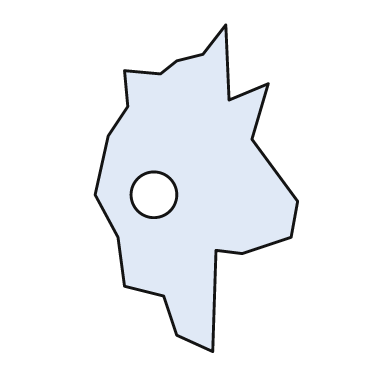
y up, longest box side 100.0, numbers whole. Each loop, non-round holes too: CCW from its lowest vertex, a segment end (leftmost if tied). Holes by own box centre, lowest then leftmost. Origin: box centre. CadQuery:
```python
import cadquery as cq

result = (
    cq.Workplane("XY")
    .moveTo(5.0, -50.0)
    .lineTo(6.0, -19.0)
    .lineTo(14.0, -20.0)
    .lineTo(29.0, -15.0)
    .lineTo(31.0, -4.0)
    .lineTo(17.0, 15.0)
    .lineTo(22.0, 32.0)
    .lineTo(10.0, 27.0)
    .lineTo(9.0, 50.0)
    .lineTo(2.0, 41.0)
    .lineTo(-6.0, 39.0)
    .lineTo(-11.0, 35.0)
    .lineTo(-22.0, 36.0)
    .lineTo(-21.0, 25.0)
    .lineTo(-27.0, 16.0)
    .lineTo(-31.0, -2.0)
    .lineTo(-24.0, -15.0)
    .lineTo(-22.0, -30.0)
    .lineTo(-10.0, -33.0)
    .lineTo(-6.0, -45.0)
    .close()
    .moveTo(-13.0, -2.0)
    .circle(7.0)
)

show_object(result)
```